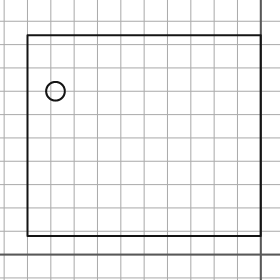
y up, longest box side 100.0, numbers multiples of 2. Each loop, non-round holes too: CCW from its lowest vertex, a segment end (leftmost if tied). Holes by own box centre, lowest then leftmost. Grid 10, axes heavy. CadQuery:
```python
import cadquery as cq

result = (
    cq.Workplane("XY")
    .moveTo(-100.0, 8.0)
    .lineTo(0.0, 8.0)
    .lineTo(0.0, 94.0)
    .lineTo(-100.0, 94.0)
    .close()
    .moveTo(-88.0, 70.0)
    .circle(4.0)
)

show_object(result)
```